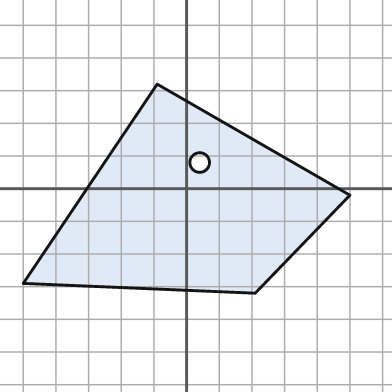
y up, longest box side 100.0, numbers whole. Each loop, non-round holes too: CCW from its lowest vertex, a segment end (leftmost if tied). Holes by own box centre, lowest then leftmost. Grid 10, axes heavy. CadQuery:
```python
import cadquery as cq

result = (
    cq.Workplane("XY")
    .moveTo(21.0, -32.0)
    .lineTo(50.0, -2.0)
    .lineTo(-9.0, 32.0)
    .lineTo(-50.0, -29.0)
    .close()
    .moveTo(4.0, 8.0)
    .circle(3.0)
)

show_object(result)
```